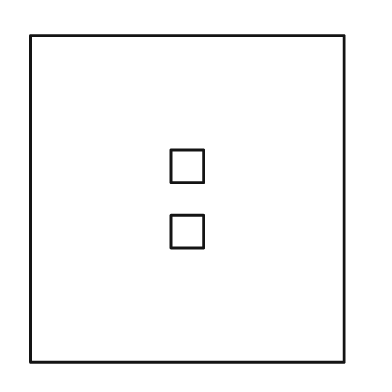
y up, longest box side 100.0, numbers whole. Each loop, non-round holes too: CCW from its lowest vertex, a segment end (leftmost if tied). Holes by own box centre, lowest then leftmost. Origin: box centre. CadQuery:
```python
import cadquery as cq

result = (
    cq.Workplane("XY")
    .moveTo(-48.0, -50.0)
    .lineTo(48.0, -50.0)
    .lineTo(48.0, 50.0)
    .lineTo(-48.0, 50.0)
    .close()
    .moveTo(-5.0, -15.0)
    .lineTo(5.0, -15.0)
    .lineTo(5.0, -5.0)
    .lineTo(-5.0, -5.0)
    .close()
    .moveTo(-5.0, 5.0)
    .lineTo(5.0, 5.0)
    .lineTo(5.0, 15.0)
    .lineTo(-5.0, 15.0)
    .close()
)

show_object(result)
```